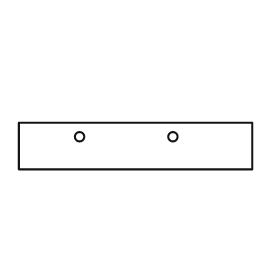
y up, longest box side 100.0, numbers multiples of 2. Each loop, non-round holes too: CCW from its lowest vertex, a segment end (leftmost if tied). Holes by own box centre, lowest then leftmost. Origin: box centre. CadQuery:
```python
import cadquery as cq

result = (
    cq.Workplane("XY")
    .moveTo(-50.0, -10.0)
    .lineTo(50.0, -10.0)
    .lineTo(50.0, 10.0)
    .lineTo(-50.0, 10.0)
    .close()
    .moveTo(-24.0, 4.0)
    .circle(2.0)
    .moveTo(16.0, 4.0)
    .circle(2.0)
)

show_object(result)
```